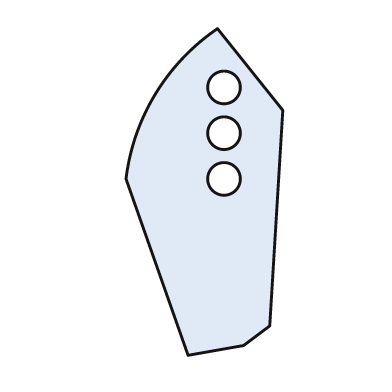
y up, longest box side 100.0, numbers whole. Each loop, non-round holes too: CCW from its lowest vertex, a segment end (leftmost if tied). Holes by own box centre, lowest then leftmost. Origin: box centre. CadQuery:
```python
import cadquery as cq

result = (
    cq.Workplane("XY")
    .moveTo(-5.0, -50.0)
    .lineTo(12.0, -47.0)
    .lineTo(20.0, -41.0)
    .lineTo(24.0, 25.0)
    .lineTo(4.0, 50.0)
    .threePointArc((-15.0, 30.0), (-24.0, 4.0))
    .close()
    .moveTo(6.0, 4.0)
    .circle(5.0)
    .moveTo(6.0, 18.0)
    .circle(5.0)
    .moveTo(6.0, 32.0)
    .circle(5.0)
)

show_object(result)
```